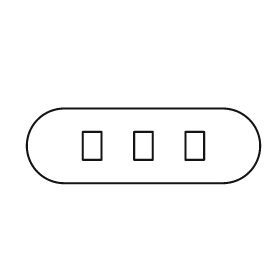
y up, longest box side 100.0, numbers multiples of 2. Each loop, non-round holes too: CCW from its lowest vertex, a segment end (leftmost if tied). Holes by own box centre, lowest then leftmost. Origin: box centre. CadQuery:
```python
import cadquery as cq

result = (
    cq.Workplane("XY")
    .moveTo(-34.0, -16.0)
    .lineTo(34.0, -16.0)
    .threePointArc((50.0, 0.0), (34.0, 16.0))
    .lineTo(-34.0, 16.0)
    .threePointArc((-50.0, 0.0), (-34.0, -16.0))
    .close()
    .moveTo(-26.0, -6.0)
    .lineTo(-18.0, -6.0)
    .lineTo(-18.0, 6.0)
    .lineTo(-26.0, 6.0)
    .close()
    .moveTo(-4.0, -6.0)
    .lineTo(4.0, -6.0)
    .lineTo(4.0, 6.0)
    .lineTo(-4.0, 6.0)
    .close()
    .moveTo(18.0, -6.0)
    .lineTo(26.0, -6.0)
    .lineTo(26.0, 6.0)
    .lineTo(18.0, 6.0)
    .close()
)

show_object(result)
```